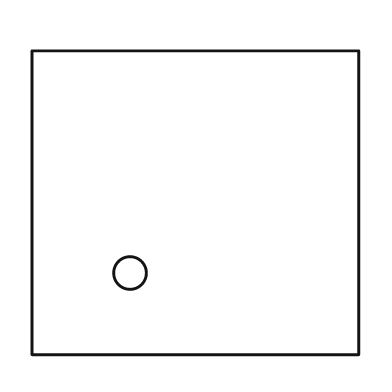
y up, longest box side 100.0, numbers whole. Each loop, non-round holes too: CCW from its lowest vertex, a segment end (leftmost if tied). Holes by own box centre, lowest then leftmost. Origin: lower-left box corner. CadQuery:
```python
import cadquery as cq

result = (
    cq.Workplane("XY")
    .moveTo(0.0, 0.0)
    .lineTo(100.0, 0.0)
    .lineTo(100.0, 93.0)
    .lineTo(0.0, 93.0)
    .close()
    .moveTo(30.0, 25.0)
    .circle(5.0)
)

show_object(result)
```